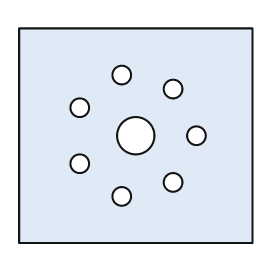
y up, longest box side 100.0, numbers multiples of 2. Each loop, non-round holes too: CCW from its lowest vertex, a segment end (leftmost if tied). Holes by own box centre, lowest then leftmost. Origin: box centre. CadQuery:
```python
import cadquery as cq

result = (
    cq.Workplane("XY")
    .moveTo(-50.0, -46.0)
    .lineTo(50.0, -46.0)
    .lineTo(50.0, 46.0)
    .lineTo(-50.0, 46.0)
    .close()
    .moveTo(-6.0, -26.0)
    .circle(4.0)
    .moveTo(16.0, -20.0)
    .circle(4.0)
    .moveTo(-24.0, -12.0)
    .circle(4.0)
    .moveTo(0.0, 0.0)
    .circle(8.0)
    .moveTo(26.0, 0.0)
    .circle(4.0)
    .moveTo(-24.0, 12.0)
    .circle(4.0)
    .moveTo(16.0, 20.0)
    .circle(4.0)
    .moveTo(-6.0, 26.0)
    .circle(4.0)
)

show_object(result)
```